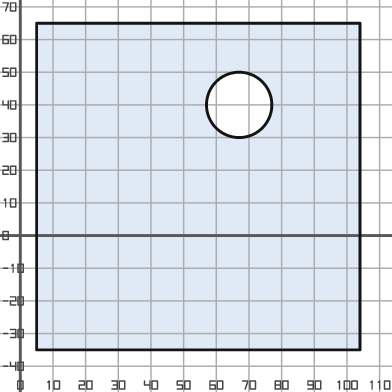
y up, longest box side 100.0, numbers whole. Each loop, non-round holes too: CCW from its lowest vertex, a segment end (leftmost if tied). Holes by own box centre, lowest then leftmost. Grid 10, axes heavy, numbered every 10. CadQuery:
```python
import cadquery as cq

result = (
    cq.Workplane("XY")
    .moveTo(5.0, -35.0)
    .lineTo(104.0, -35.0)
    .lineTo(104.0, 65.0)
    .lineTo(5.0, 65.0)
    .close()
    .moveTo(67.0, 40.0)
    .circle(10.0)
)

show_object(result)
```